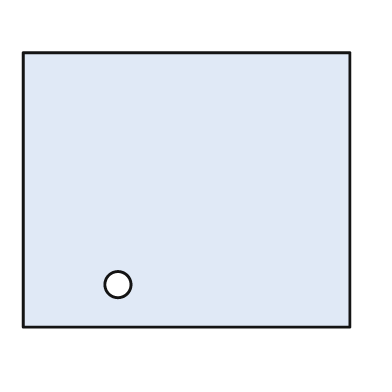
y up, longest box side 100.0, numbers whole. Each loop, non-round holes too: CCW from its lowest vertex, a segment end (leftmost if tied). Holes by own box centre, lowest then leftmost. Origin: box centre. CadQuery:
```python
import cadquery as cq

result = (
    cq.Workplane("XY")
    .moveTo(-50.0, -42.0)
    .lineTo(50.0, -42.0)
    .lineTo(50.0, 42.0)
    .lineTo(-50.0, 42.0)
    .close()
    .moveTo(-21.0, -29.0)
    .circle(4.0)
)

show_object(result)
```